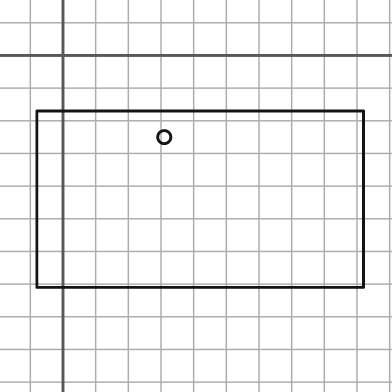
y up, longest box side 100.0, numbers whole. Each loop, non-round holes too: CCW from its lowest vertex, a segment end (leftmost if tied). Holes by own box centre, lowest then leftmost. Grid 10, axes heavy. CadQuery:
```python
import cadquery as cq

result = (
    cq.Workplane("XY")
    .moveTo(-8.0, -71.0)
    .lineTo(92.0, -71.0)
    .lineTo(92.0, -17.0)
    .lineTo(-8.0, -17.0)
    .close()
    .moveTo(31.0, -25.0)
    .circle(2.0)
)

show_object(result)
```